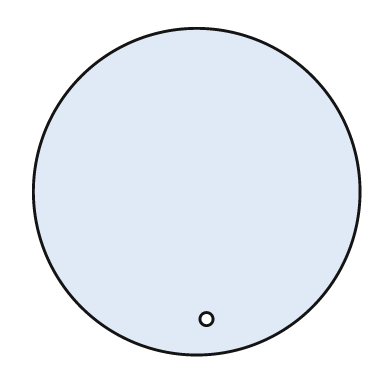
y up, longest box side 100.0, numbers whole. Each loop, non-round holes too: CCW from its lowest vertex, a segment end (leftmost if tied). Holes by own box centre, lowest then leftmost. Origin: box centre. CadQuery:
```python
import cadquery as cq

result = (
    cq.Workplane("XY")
    .moveTo(0.0, 0.0)
    .circle(50.0)
    .moveTo(3.0, -39.0)
    .circle(2.0)
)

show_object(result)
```